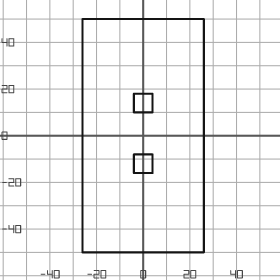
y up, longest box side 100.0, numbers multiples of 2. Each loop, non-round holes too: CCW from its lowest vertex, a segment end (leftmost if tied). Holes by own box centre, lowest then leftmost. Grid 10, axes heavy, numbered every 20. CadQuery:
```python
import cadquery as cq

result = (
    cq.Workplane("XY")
    .moveTo(-26.0, -50.0)
    .lineTo(26.0, -50.0)
    .lineTo(26.0, 50.0)
    .lineTo(-26.0, 50.0)
    .close()
    .moveTo(-4.0, -16.0)
    .lineTo(4.0, -16.0)
    .lineTo(4.0, -8.0)
    .lineTo(-4.0, -8.0)
    .close()
    .moveTo(-4.0, 10.0)
    .lineTo(4.0, 10.0)
    .lineTo(4.0, 18.0)
    .lineTo(-4.0, 18.0)
    .close()
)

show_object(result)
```